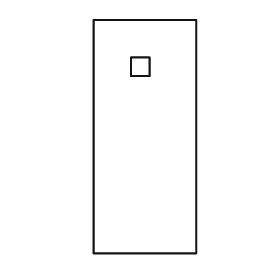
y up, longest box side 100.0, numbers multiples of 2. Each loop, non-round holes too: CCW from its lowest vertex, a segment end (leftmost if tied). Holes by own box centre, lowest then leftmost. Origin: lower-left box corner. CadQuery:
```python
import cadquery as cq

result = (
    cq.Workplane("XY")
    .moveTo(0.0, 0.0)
    .lineTo(44.0, 0.0)
    .lineTo(44.0, 100.0)
    .lineTo(0.0, 100.0)
    .close()
    .moveTo(16.0, 76.0)
    .lineTo(24.0, 76.0)
    .lineTo(24.0, 84.0)
    .lineTo(16.0, 84.0)
    .close()
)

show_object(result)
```